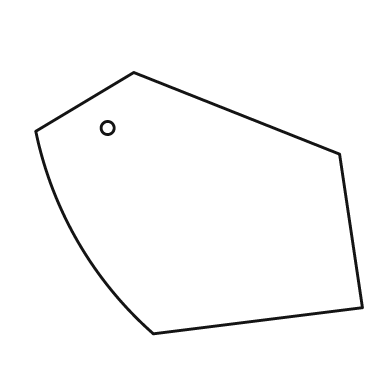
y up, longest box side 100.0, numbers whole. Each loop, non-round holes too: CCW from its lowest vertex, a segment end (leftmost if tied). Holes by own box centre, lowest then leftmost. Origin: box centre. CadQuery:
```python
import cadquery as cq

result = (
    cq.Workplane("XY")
    .moveTo(-14.0, -40.0)
    .lineTo(50.0, -32.0)
    .lineTo(43.0, 15.0)
    .lineTo(-20.0, 40.0)
    .lineTo(-50.0, 22.0)
    .threePointArc((-37.0, -12.0), (-14.0, -40.0))
    .close()
    .moveTo(-28.0, 23.0)
    .circle(2.0)
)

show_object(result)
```